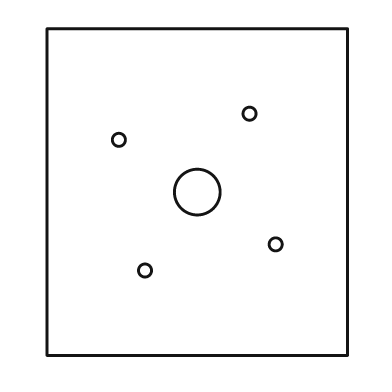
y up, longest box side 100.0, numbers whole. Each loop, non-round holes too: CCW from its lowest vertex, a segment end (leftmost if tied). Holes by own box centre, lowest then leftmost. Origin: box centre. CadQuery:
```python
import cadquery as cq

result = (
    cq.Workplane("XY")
    .moveTo(-46.0, -50.0)
    .lineTo(46.0, -50.0)
    .lineTo(46.0, 50.0)
    .lineTo(-46.0, 50.0)
    .close()
    .moveTo(-16.0, -24.0)
    .circle(2.0)
    .moveTo(24.0, -16.0)
    .circle(2.0)
    .moveTo(0.0, 0.0)
    .circle(7.0)
    .moveTo(-24.0, 16.0)
    .circle(2.0)
    .moveTo(16.0, 24.0)
    .circle(2.0)
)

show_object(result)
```